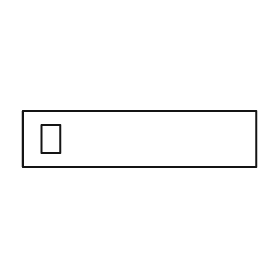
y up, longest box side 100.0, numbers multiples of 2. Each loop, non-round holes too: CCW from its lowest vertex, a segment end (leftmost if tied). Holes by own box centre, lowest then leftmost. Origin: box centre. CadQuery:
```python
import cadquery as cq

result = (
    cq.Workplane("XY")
    .moveTo(-50.0, -12.0)
    .lineTo(50.0, -12.0)
    .lineTo(50.0, 12.0)
    .lineTo(-50.0, 12.0)
    .close()
    .moveTo(-42.0, -6.0)
    .lineTo(-34.0, -6.0)
    .lineTo(-34.0, 6.0)
    .lineTo(-42.0, 6.0)
    .close()
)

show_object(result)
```